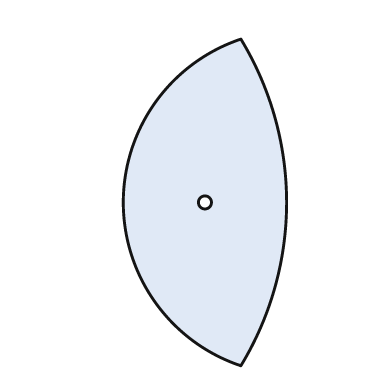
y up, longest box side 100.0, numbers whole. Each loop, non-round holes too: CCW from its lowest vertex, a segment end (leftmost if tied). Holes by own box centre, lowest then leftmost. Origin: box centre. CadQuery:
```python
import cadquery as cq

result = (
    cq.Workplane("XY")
    .moveTo(11.0, -50.0)
    .threePointArc((25.0, 0.0), (11.0, 50.0))
    .threePointArc((-25.0, 0.0), (11.0, -50.0))
    .close()
    .moveTo(0.0, 0.0)
    .circle(2.0)
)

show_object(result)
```